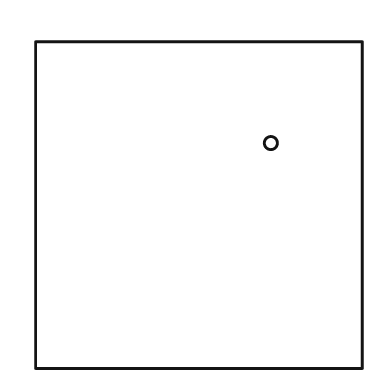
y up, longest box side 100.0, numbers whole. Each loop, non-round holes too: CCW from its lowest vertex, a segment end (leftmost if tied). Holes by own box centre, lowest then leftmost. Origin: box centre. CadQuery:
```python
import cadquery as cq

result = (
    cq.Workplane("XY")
    .moveTo(-50.0, -50.0)
    .lineTo(50.0, -50.0)
    .lineTo(50.0, 50.0)
    .lineTo(-50.0, 50.0)
    .close()
    .moveTo(22.0, 19.0)
    .circle(2.0)
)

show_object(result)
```